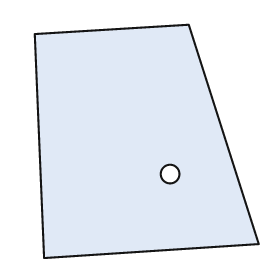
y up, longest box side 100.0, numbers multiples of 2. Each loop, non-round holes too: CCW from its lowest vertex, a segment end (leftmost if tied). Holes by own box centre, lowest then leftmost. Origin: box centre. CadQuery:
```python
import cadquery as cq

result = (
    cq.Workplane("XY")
    .moveTo(-44.0, -50.0)
    .lineTo(48.0, -44.0)
    .lineTo(18.0, 50.0)
    .lineTo(-48.0, 46.0)
    .close()
    .moveTo(10.0, -14.0)
    .circle(4.0)
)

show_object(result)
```